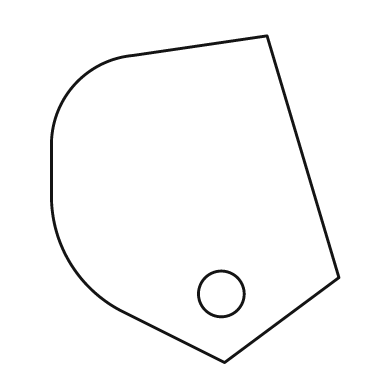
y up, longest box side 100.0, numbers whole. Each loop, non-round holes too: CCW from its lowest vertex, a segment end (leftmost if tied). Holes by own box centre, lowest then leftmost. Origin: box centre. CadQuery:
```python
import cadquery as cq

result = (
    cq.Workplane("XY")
    .moveTo(9.0, -50.0)
    .lineTo(44.0, -24.0)
    .lineTo(22.0, 50.0)
    .lineTo(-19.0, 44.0)
    .threePointArc((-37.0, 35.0), (-44.0, 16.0))
    .lineTo(-44.0, 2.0)
    .threePointArc((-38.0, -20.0), (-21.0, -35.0))
    .close()
    .moveTo(8.0, -29.0)
    .circle(7.0)
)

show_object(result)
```